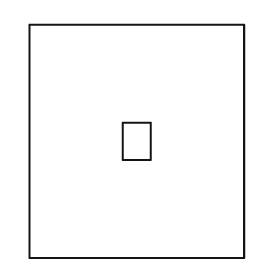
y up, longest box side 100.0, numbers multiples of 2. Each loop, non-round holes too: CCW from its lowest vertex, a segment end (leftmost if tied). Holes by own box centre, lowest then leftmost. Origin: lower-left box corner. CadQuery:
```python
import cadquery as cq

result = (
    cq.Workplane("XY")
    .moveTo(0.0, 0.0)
    .lineTo(92.0, 0.0)
    .lineTo(92.0, 100.0)
    .lineTo(0.0, 100.0)
    .close()
    .moveTo(40.0, 42.0)
    .lineTo(52.0, 42.0)
    .lineTo(52.0, 58.0)
    .lineTo(40.0, 58.0)
    .close()
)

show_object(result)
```